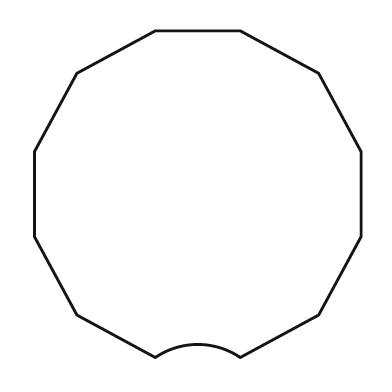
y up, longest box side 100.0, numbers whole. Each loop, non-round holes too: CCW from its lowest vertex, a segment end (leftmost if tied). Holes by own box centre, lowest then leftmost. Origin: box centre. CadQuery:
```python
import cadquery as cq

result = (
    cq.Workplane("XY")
    .moveTo(-13.0, -50.0)
    .threePointArc((0.0, -46.0), (13.0, -50.0))
    .lineTo(37.0, -37.0)
    .lineTo(50.0, -13.0)
    .lineTo(50.0, 13.0)
    .lineTo(37.0, 37.0)
    .lineTo(13.0, 50.0)
    .lineTo(-13.0, 50.0)
    .lineTo(-37.0, 37.0)
    .lineTo(-50.0, 13.0)
    .lineTo(-50.0, -13.0)
    .lineTo(-37.0, -37.0)
    .close()
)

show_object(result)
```